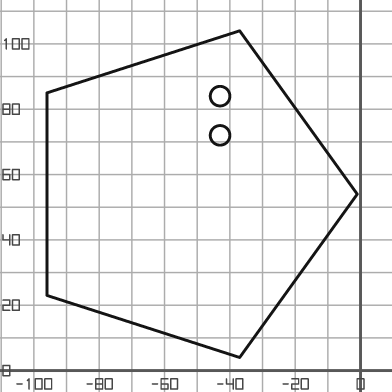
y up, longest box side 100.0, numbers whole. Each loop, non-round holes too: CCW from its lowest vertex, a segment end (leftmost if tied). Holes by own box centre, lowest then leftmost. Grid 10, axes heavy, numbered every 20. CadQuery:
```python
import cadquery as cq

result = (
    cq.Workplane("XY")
    .moveTo(-37.0, 4.0)
    .lineTo(-1.0, 54.0)
    .lineTo(-37.0, 104.0)
    .lineTo(-96.0, 85.0)
    .lineTo(-96.0, 23.0)
    .close()
    .moveTo(-43.0, 72.0)
    .circle(3.0)
    .moveTo(-43.0, 84.0)
    .circle(3.0)
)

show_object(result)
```